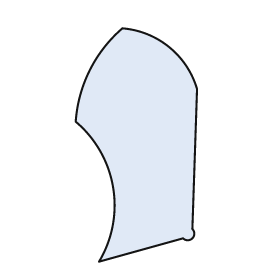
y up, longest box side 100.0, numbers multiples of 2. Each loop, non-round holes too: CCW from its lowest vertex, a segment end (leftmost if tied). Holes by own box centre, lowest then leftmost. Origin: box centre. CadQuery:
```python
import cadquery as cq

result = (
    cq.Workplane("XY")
    .moveTo(-16.0, -50.0)
    .lineTo(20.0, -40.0)
    .threePointArc((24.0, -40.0), (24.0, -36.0))
    .lineTo(26.0, 24.0)
    .threePointArc((14.0, 42.0), (-6.0, 50.0))
    .threePointArc((-20.0, 32.0), (-26.0, 10.0))
    .threePointArc((-10.0, -18.0), (-16.0, -50.0))
    .close()
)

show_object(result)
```